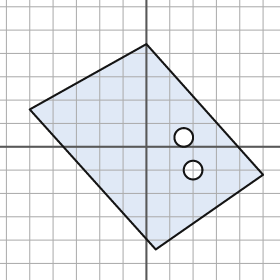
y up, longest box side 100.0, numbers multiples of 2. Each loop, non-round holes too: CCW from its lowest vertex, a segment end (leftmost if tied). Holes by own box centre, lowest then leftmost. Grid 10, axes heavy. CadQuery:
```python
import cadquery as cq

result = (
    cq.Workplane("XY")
    .moveTo(4.0, -44.0)
    .lineTo(50.0, -12.0)
    .lineTo(0.0, 44.0)
    .lineTo(-50.0, 16.0)
    .close()
    .moveTo(20.0, -10.0)
    .circle(4.0)
    .moveTo(16.0, 4.0)
    .circle(4.0)
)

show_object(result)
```